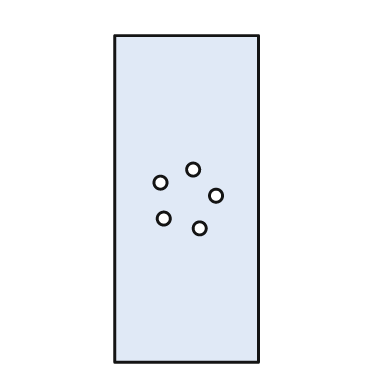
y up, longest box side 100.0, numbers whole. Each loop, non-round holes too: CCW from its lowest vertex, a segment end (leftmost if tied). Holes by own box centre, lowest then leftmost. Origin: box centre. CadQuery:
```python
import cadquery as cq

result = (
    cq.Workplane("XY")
    .moveTo(-22.0, -50.0)
    .lineTo(22.0, -50.0)
    .lineTo(22.0, 50.0)
    .lineTo(-22.0, 50.0)
    .close()
    .moveTo(4.0, -9.0)
    .circle(2.0)
    .moveTo(-7.0, -6.0)
    .circle(2.0)
    .moveTo(9.0, 1.0)
    .circle(2.0)
    .moveTo(-8.0, 5.0)
    .circle(2.0)
    .moveTo(2.0, 9.0)
    .circle(2.0)
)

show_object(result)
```